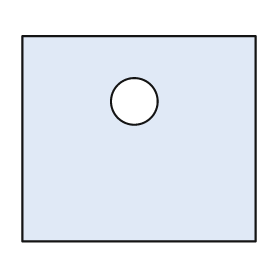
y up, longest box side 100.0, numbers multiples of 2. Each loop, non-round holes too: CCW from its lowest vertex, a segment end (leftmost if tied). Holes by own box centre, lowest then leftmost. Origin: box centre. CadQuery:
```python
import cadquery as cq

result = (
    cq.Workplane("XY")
    .moveTo(-50.0, -44.0)
    .lineTo(50.0, -44.0)
    .lineTo(50.0, 44.0)
    .lineTo(-50.0, 44.0)
    .close()
    .moveTo(-2.0, 16.0)
    .circle(10.0)
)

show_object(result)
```